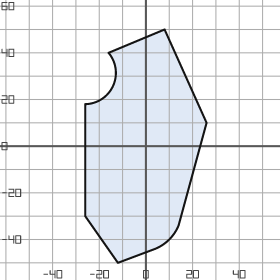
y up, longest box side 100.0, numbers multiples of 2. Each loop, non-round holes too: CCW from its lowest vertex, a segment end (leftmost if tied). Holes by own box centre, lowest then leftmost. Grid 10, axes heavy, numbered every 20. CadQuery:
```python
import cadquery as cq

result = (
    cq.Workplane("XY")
    .moveTo(-12.0, -50.0)
    .lineTo(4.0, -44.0)
    .threePointArc((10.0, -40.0), (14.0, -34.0))
    .lineTo(26.0, 10.0)
    .lineTo(8.0, 50.0)
    .lineTo(-16.0, 40.0)
    .threePointArc((-14.0, 26.0), (-26.0, 18.0))
    .lineTo(-26.0, -30.0)
    .close()
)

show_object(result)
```